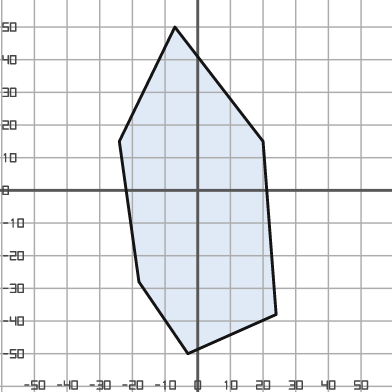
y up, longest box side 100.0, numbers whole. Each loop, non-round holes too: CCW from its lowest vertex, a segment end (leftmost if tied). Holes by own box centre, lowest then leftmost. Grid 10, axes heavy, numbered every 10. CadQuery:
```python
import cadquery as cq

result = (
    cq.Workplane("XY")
    .moveTo(-3.0, -50.0)
    .lineTo(24.0, -38.0)
    .lineTo(20.0, 15.0)
    .lineTo(-7.0, 50.0)
    .lineTo(-24.0, 15.0)
    .lineTo(-18.0, -28.0)
    .close()
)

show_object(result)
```